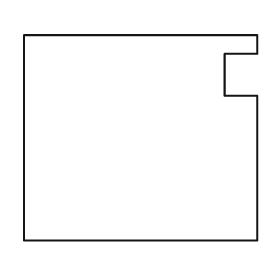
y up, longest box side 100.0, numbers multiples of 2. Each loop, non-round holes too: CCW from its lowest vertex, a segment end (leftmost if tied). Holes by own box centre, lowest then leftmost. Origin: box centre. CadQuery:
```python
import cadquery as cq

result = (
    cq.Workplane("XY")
    .moveTo(-50.0, -44.0)
    .lineTo(50.0, -44.0)
    .lineTo(50.0, 18.0)
    .lineTo(36.0, 18.0)
    .lineTo(36.0, 36.0)
    .lineTo(50.0, 36.0)
    .lineTo(50.0, 44.0)
    .lineTo(-50.0, 44.0)
    .close()
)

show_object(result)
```